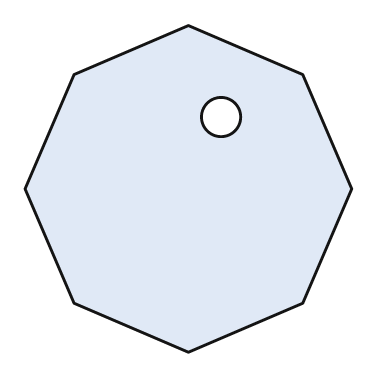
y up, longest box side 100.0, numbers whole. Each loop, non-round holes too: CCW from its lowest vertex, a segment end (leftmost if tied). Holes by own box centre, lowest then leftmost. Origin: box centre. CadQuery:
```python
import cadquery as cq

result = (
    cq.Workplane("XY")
    .moveTo(0.0, -50.0)
    .lineTo(35.0, -35.0)
    .lineTo(50.0, 0.0)
    .lineTo(35.0, 35.0)
    .lineTo(0.0, 50.0)
    .lineTo(-35.0, 35.0)
    .lineTo(-50.0, 0.0)
    .lineTo(-35.0, -35.0)
    .close()
    .moveTo(10.0, 22.0)
    .circle(6.0)
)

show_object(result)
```